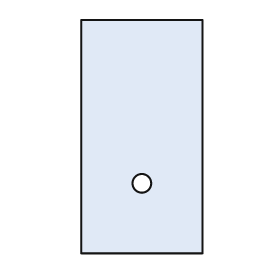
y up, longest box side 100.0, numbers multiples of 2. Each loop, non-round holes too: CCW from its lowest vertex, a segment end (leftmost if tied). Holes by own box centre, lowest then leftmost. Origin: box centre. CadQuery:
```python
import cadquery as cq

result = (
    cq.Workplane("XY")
    .moveTo(-26.0, -50.0)
    .lineTo(26.0, -50.0)
    .lineTo(26.0, 50.0)
    .lineTo(-26.0, 50.0)
    .close()
    .moveTo(0.0, -20.0)
    .circle(4.0)
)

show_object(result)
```